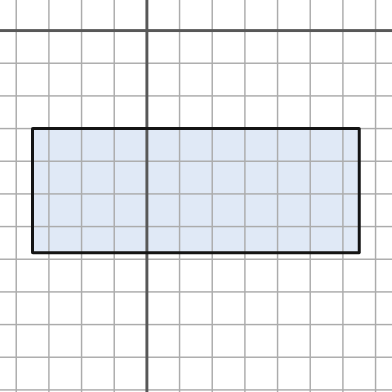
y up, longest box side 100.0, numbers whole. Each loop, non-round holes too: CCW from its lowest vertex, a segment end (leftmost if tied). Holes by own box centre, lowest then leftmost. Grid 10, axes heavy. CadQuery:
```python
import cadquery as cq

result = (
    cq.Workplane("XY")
    .moveTo(-35.0, -68.0)
    .lineTo(65.0, -68.0)
    .lineTo(65.0, -30.0)
    .lineTo(-35.0, -30.0)
    .close()
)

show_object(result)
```